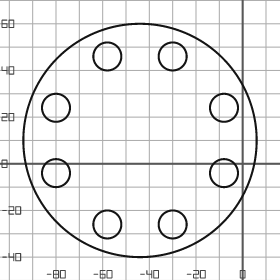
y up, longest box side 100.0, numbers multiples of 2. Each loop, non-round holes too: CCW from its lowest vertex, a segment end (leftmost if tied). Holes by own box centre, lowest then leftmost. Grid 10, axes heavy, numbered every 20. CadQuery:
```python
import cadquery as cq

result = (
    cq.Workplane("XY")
    .moveTo(-44.0, 10.0)
    .circle(50.0)
    .moveTo(-58.0, -26.0)
    .circle(6.0)
    .moveTo(-30.0, -26.0)
    .circle(6.0)
    .moveTo(-80.0, -4.0)
    .circle(6.0)
    .moveTo(-8.0, -4.0)
    .circle(6.0)
    .moveTo(-80.0, 24.0)
    .circle(6.0)
    .moveTo(-8.0, 24.0)
    .circle(6.0)
    .moveTo(-58.0, 46.0)
    .circle(6.0)
    .moveTo(-30.0, 46.0)
    .circle(6.0)
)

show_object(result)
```